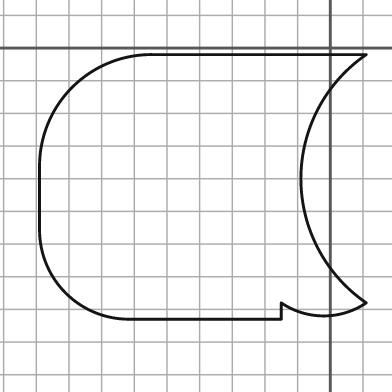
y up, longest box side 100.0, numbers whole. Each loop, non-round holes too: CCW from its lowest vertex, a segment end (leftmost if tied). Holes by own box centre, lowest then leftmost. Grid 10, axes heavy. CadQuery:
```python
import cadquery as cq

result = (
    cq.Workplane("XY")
    .moveTo(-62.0, -83.0)
    .lineTo(-15.0, -83.0)
    .lineTo(-15.0, -78.0)
    .threePointArc((-2.0, -82.0), (11.0, -78.0))
    .threePointArc((-9.0, -40.0), (11.0, -2.0))
    .lineTo(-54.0, -2.0)
    .threePointArc((-79.0, -12.0), (-89.0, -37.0))
    .lineTo(-89.0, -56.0)
    .threePointArc((-81.0, -75.0), (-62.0, -83.0))
    .close()
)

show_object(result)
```